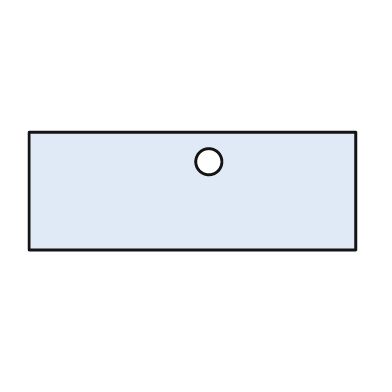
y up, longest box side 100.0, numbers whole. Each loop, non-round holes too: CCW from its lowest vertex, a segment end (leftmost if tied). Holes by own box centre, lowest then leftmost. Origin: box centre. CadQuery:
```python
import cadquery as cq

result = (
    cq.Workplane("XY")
    .moveTo(-50.0, -18.0)
    .lineTo(50.0, -18.0)
    .lineTo(50.0, 18.0)
    .lineTo(-50.0, 18.0)
    .close()
    .moveTo(5.0, 9.0)
    .circle(4.0)
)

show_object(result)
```